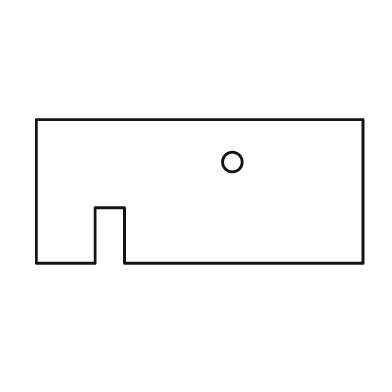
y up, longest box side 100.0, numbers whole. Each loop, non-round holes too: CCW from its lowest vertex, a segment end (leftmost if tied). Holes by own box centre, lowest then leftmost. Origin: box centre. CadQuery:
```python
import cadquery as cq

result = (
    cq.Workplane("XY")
    .moveTo(-50.0, -22.0)
    .lineTo(-32.0, -22.0)
    .lineTo(-32.0, -5.0)
    .lineTo(-23.0, -5.0)
    .lineTo(-23.0, -22.0)
    .lineTo(50.0, -22.0)
    .lineTo(50.0, 22.0)
    .lineTo(-50.0, 22.0)
    .close()
    .moveTo(10.0, 9.0)
    .circle(3.0)
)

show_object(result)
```